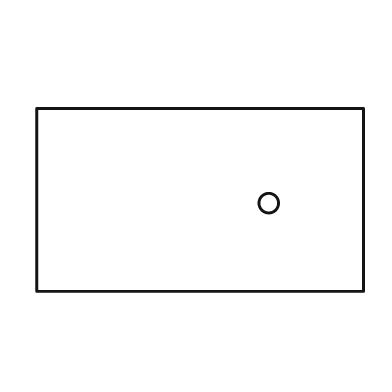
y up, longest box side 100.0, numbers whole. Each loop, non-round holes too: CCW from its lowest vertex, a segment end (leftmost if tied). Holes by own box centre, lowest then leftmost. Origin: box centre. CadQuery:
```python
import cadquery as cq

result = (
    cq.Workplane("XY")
    .moveTo(-50.0, -28.0)
    .lineTo(50.0, -28.0)
    .lineTo(50.0, 28.0)
    .lineTo(-50.0, 28.0)
    .close()
    .moveTo(21.0, -1.0)
    .circle(3.0)
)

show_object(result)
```